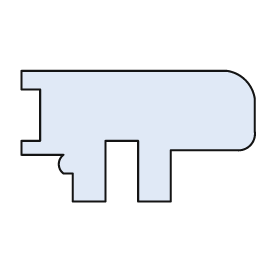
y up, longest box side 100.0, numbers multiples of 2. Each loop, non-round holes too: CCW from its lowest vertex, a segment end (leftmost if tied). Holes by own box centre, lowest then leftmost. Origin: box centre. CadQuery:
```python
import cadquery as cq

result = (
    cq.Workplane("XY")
    .moveTo(-28.0, -28.0)
    .lineTo(-14.0, -28.0)
    .lineTo(-14.0, -2.0)
    .lineTo(0.0, -2.0)
    .lineTo(0.0, -28.0)
    .lineTo(14.0, -28.0)
    .lineTo(14.0, -6.0)
    .lineTo(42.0, -6.0)
    .threePointArc((48.0, -4.0), (50.0, 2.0))
    .lineTo(50.0, 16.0)
    .threePointArc((46.0, 24.0), (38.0, 28.0))
    .lineTo(-50.0, 28.0)
    .lineTo(-50.0, 20.0)
    .lineTo(-42.0, 20.0)
    .lineTo(-42.0, -2.0)
    .lineTo(-50.0, -2.0)
    .lineTo(-50.0, -8.0)
    .lineTo(-32.0, -8.0)
    .threePointArc((-34.0, -12.0), (-32.0, -16.0))
    .lineTo(-28.0, -16.0)
    .close()
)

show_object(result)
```